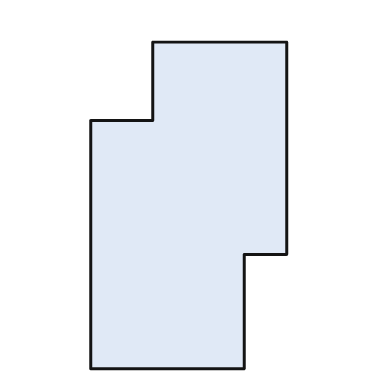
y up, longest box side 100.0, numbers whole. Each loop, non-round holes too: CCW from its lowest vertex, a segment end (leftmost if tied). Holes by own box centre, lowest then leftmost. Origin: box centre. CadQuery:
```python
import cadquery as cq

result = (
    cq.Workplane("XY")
    .moveTo(-30.0, -50.0)
    .lineTo(17.0, -50.0)
    .lineTo(17.0, -15.0)
    .lineTo(30.0, -15.0)
    .lineTo(30.0, 50.0)
    .lineTo(-11.0, 50.0)
    .lineTo(-11.0, 26.0)
    .lineTo(-30.0, 26.0)
    .close()
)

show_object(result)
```